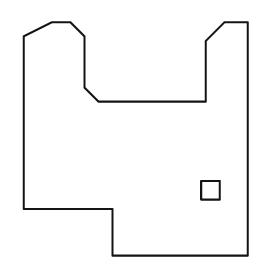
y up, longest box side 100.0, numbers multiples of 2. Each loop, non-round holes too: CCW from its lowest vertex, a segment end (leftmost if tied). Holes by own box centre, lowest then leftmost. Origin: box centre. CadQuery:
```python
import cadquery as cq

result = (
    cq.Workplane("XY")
    .moveTo(-10.0, -50.0)
    .lineTo(48.0, -50.0)
    .lineTo(48.0, 50.0)
    .lineTo(38.0, 50.0)
    .lineTo(30.0, 42.0)
    .lineTo(30.0, 16.0)
    .lineTo(-16.0, 16.0)
    .lineTo(-22.0, 22.0)
    .lineTo(-22.0, 44.0)
    .lineTo(-28.0, 50.0)
    .lineTo(-36.0, 50.0)
    .lineTo(-48.0, 44.0)
    .lineTo(-48.0, -30.0)
    .lineTo(-10.0, -30.0)
    .close()
    .moveTo(28.0, -26.0)
    .lineTo(36.0, -26.0)
    .lineTo(36.0, -18.0)
    .lineTo(28.0, -18.0)
    .close()
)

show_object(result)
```